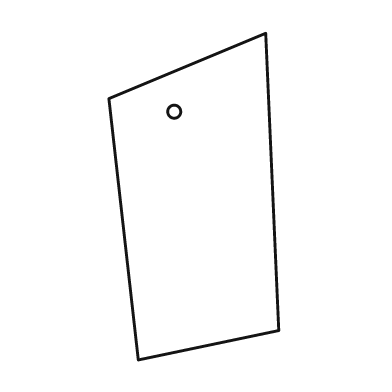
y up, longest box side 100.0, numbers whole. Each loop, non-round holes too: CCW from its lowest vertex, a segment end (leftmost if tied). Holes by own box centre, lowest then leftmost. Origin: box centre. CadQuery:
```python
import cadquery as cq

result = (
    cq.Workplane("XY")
    .moveTo(-17.0, -50.0)
    .lineTo(26.0, -41.0)
    .lineTo(22.0, 50.0)
    .lineTo(-26.0, 30.0)
    .close()
    .moveTo(-6.0, 26.0)
    .circle(2.0)
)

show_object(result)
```